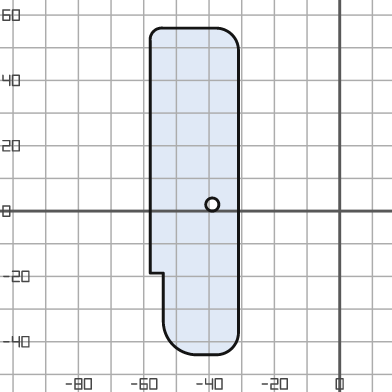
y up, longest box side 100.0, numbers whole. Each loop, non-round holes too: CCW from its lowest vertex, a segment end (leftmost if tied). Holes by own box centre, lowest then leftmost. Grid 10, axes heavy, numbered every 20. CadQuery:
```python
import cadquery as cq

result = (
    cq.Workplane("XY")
    .moveTo(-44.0, -44.0)
    .lineTo(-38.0, -44.0)
    .threePointArc((-33.0, -42.0), (-31.0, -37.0))
    .lineTo(-31.0, 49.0)
    .threePointArc((-33.0, 54.0), (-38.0, 56.0))
    .lineTo(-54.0, 56.0)
    .threePointArc((-57.0, 55.0), (-58.0, 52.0))
    .lineTo(-58.0, -19.0)
    .lineTo(-54.0, -19.0)
    .lineTo(-54.0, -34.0)
    .threePointArc((-51.0, -41.0), (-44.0, -44.0))
    .close()
    .moveTo(-39.0, 2.0)
    .circle(2.0)
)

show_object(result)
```